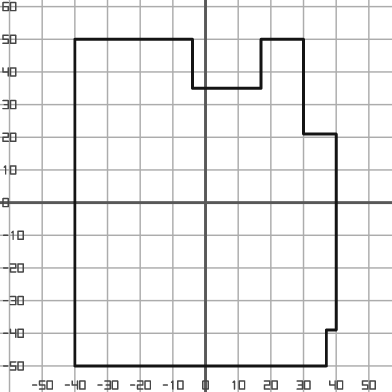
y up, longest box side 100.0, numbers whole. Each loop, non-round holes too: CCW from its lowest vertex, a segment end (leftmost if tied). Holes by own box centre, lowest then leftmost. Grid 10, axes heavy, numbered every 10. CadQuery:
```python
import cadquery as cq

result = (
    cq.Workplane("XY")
    .moveTo(-40.0, -50.0)
    .lineTo(37.0, -50.0)
    .lineTo(37.0, -39.0)
    .lineTo(40.0, -39.0)
    .lineTo(40.0, 21.0)
    .lineTo(30.0, 21.0)
    .lineTo(30.0, 50.0)
    .lineTo(17.0, 50.0)
    .lineTo(17.0, 35.0)
    .lineTo(-4.0, 35.0)
    .lineTo(-4.0, 50.0)
    .lineTo(-40.0, 50.0)
    .close()
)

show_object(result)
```